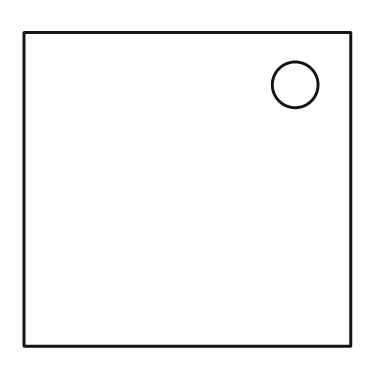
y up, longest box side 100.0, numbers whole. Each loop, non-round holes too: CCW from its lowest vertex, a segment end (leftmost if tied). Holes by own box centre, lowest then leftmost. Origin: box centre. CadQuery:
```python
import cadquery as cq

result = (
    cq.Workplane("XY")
    .moveTo(-50.0, -48.0)
    .lineTo(50.0, -48.0)
    .lineTo(50.0, 48.0)
    .lineTo(-50.0, 48.0)
    .close()
    .moveTo(33.0, 32.0)
    .circle(7.0)
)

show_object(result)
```